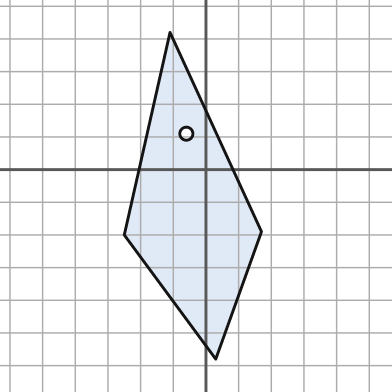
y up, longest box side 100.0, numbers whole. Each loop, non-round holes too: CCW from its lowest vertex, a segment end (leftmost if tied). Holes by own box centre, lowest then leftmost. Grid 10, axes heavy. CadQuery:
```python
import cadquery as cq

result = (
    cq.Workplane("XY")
    .moveTo(3.0, -58.0)
    .lineTo(17.0, -19.0)
    .lineTo(-11.0, 42.0)
    .lineTo(-25.0, -20.0)
    .close()
    .moveTo(-6.0, 11.0)
    .circle(2.0)
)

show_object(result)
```